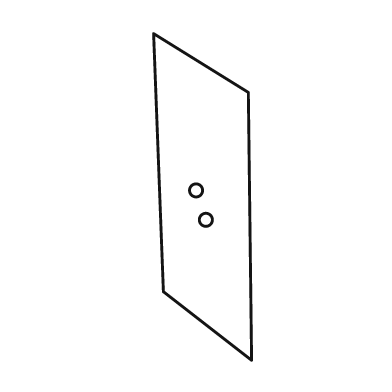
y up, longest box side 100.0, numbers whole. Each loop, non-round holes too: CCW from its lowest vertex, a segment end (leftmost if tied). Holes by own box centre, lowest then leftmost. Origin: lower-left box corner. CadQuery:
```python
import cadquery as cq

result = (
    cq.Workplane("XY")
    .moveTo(30.0, 0.0)
    .lineTo(29.0, 82.0)
    .lineTo(0.0, 100.0)
    .lineTo(3.0, 21.0)
    .close()
    .moveTo(16.0, 43.0)
    .circle(2.0)
    .moveTo(13.0, 52.0)
    .circle(2.0)
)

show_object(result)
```